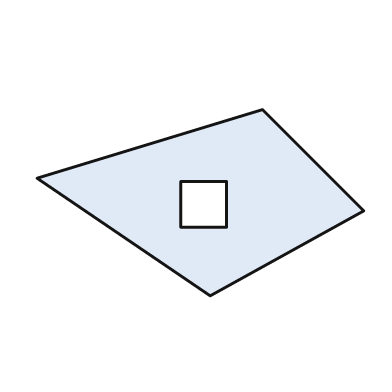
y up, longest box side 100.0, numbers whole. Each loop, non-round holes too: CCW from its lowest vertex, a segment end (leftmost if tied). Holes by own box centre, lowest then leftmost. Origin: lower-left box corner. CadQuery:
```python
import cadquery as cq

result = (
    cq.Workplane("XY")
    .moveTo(53.0, 0.0)
    .lineTo(100.0, 26.0)
    .lineTo(69.0, 57.0)
    .lineTo(0.0, 36.0)
    .close()
    .moveTo(44.0, 21.0)
    .lineTo(58.0, 21.0)
    .lineTo(58.0, 35.0)
    .lineTo(44.0, 35.0)
    .close()
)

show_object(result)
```